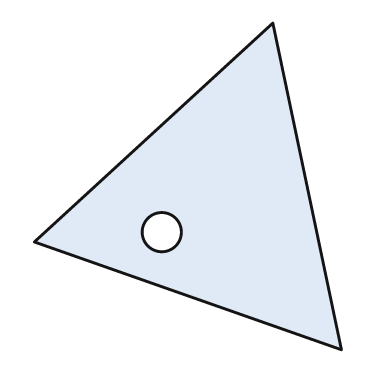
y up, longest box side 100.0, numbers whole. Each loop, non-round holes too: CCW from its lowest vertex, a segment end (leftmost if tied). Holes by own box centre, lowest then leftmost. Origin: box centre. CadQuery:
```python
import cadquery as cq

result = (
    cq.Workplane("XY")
    .moveTo(47.0, -50.0)
    .lineTo(26.0, 50.0)
    .lineTo(-47.0, -17.0)
    .close()
    .moveTo(-8.0, -14.0)
    .circle(6.0)
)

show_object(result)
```